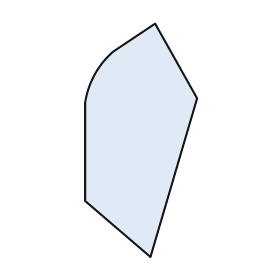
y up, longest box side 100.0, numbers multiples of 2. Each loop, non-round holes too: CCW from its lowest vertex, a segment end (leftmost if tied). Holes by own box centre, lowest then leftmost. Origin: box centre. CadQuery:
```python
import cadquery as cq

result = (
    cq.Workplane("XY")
    .moveTo(4.0, -50.0)
    .lineTo(24.0, 18.0)
    .lineTo(6.0, 50.0)
    .lineTo(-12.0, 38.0)
    .threePointArc((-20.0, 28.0), (-24.0, 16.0))
    .lineTo(-24.0, -26.0)
    .close()
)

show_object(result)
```